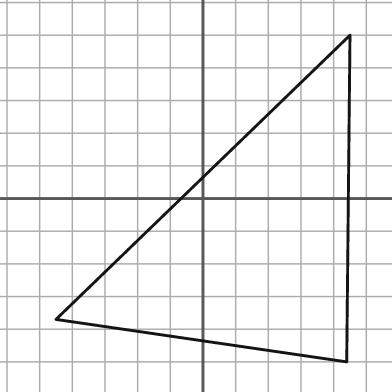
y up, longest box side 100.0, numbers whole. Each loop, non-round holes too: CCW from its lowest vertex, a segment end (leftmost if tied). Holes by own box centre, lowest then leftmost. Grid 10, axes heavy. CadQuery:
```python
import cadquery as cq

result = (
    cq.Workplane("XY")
    .moveTo(44.0, -50.0)
    .lineTo(45.0, 50.0)
    .lineTo(-45.0, -37.0)
    .close()
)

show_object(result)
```